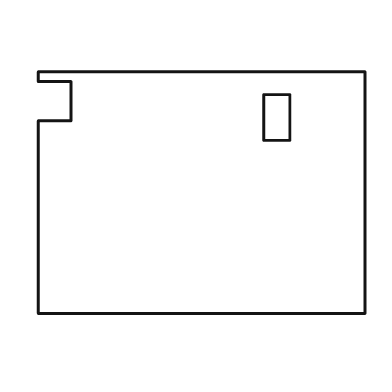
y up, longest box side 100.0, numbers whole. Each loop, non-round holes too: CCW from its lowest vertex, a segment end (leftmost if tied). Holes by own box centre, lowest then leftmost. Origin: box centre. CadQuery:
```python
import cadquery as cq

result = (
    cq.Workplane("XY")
    .moveTo(-50.0, -37.0)
    .lineTo(50.0, -37.0)
    .lineTo(50.0, 37.0)
    .lineTo(-50.0, 37.0)
    .lineTo(-50.0, 34.0)
    .lineTo(-40.0, 34.0)
    .lineTo(-40.0, 22.0)
    .lineTo(-50.0, 22.0)
    .close()
    .moveTo(19.0, 16.0)
    .lineTo(27.0, 16.0)
    .lineTo(27.0, 30.0)
    .lineTo(19.0, 30.0)
    .close()
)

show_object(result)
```